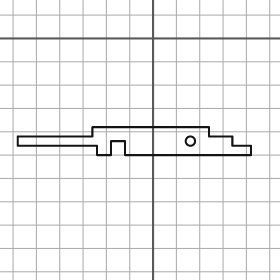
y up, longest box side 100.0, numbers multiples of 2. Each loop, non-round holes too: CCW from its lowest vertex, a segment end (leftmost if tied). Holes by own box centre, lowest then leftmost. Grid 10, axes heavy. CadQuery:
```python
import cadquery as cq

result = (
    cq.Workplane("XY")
    .moveTo(-24.0, -50.0)
    .lineTo(-18.0, -50.0)
    .lineTo(-18.0, -44.0)
    .lineTo(-12.0, -44.0)
    .lineTo(-12.0, -50.0)
    .lineTo(42.0, -50.0)
    .lineTo(42.0, -46.0)
    .lineTo(34.0, -46.0)
    .lineTo(34.0, -42.0)
    .lineTo(24.0, -42.0)
    .lineTo(24.0, -38.0)
    .lineTo(-26.0, -38.0)
    .lineTo(-26.0, -42.0)
    .lineTo(-58.0, -42.0)
    .lineTo(-58.0, -46.0)
    .lineTo(-24.0, -46.0)
    .close()
    .moveTo(16.0, -44.0)
    .circle(2.0)
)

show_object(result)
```